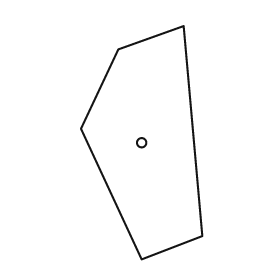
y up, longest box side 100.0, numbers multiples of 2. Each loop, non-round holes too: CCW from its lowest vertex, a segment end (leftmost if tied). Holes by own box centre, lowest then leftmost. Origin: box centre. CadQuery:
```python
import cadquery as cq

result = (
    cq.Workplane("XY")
    .moveTo(0.0, -50.0)
    .lineTo(26.0, -40.0)
    .lineTo(18.0, 50.0)
    .lineTo(-10.0, 40.0)
    .lineTo(-26.0, 6.0)
    .close()
    .moveTo(0.0, 0.0)
    .circle(2.0)
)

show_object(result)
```